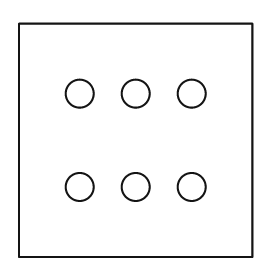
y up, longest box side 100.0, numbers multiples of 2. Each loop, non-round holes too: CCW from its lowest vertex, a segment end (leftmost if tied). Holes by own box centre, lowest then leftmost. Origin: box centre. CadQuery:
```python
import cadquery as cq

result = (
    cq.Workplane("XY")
    .moveTo(-50.0, -50.0)
    .lineTo(50.0, -50.0)
    .lineTo(50.0, 50.0)
    .lineTo(-50.0, 50.0)
    .close()
    .moveTo(-24.0, -20.0)
    .circle(6.0)
    .moveTo(0.0, -20.0)
    .circle(6.0)
    .moveTo(24.0, -20.0)
    .circle(6.0)
    .moveTo(-24.0, 20.0)
    .circle(6.0)
    .moveTo(0.0, 20.0)
    .circle(6.0)
    .moveTo(24.0, 20.0)
    .circle(6.0)
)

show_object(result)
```